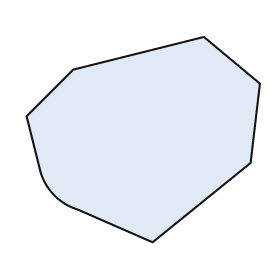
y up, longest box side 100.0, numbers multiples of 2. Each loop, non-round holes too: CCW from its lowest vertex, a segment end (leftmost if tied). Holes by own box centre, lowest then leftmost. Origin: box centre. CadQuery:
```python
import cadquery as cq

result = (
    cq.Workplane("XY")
    .moveTo(4.0, -44.0)
    .lineTo(46.0, -10.0)
    .lineTo(50.0, 24.0)
    .lineTo(26.0, 44.0)
    .lineTo(-30.0, 30.0)
    .lineTo(-50.0, 10.0)
    .lineTo(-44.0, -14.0)
    .threePointArc((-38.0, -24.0), (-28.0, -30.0))
    .close()
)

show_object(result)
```